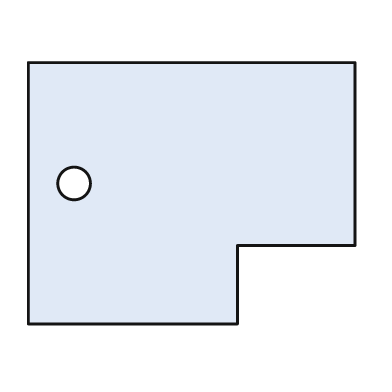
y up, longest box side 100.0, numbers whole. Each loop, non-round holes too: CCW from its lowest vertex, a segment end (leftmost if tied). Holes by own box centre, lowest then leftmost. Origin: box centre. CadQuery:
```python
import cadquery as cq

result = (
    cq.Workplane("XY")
    .moveTo(-50.0, -40.0)
    .lineTo(14.0, -40.0)
    .lineTo(14.0, -16.0)
    .lineTo(50.0, -16.0)
    .lineTo(50.0, 40.0)
    .lineTo(-50.0, 40.0)
    .close()
    .moveTo(-36.0, 3.0)
    .circle(5.0)
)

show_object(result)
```